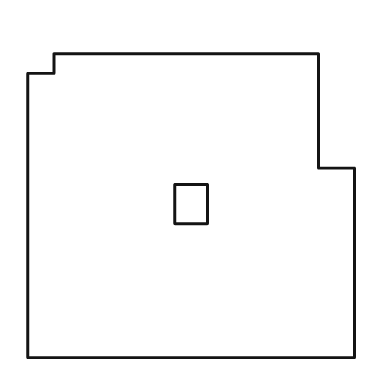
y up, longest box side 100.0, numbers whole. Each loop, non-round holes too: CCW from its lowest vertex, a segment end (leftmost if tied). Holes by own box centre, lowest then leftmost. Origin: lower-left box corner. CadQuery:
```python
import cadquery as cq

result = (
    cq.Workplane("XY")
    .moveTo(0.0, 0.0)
    .lineTo(100.0, 0.0)
    .lineTo(100.0, 58.0)
    .lineTo(89.0, 58.0)
    .lineTo(89.0, 93.0)
    .lineTo(8.0, 93.0)
    .lineTo(8.0, 87.0)
    .lineTo(0.0, 87.0)
    .close()
    .moveTo(45.0, 41.0)
    .lineTo(55.0, 41.0)
    .lineTo(55.0, 53.0)
    .lineTo(45.0, 53.0)
    .close()
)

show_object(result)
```